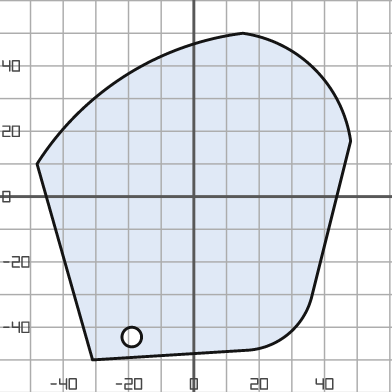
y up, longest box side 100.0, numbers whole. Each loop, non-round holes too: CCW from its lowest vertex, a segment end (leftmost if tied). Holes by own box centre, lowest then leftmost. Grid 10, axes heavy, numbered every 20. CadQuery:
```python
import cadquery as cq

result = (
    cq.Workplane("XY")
    .moveTo(-31.0, -50.0)
    .lineTo(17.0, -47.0)
    .threePointArc((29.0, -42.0), (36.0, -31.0))
    .lineTo(48.0, 17.0)
    .threePointArc((37.0, 39.0), (15.0, 50.0))
    .threePointArc((-21.0, 37.0), (-48.0, 10.0))
    .close()
    .moveTo(-19.0, -43.0)
    .circle(3.0)
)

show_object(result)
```